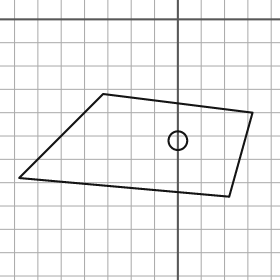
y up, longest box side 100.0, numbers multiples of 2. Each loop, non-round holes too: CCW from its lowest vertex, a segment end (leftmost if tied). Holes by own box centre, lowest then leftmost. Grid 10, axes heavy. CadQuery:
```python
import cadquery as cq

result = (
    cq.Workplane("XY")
    .moveTo(22.0, -76.0)
    .lineTo(32.0, -40.0)
    .lineTo(-32.0, -32.0)
    .lineTo(-68.0, -68.0)
    .close()
    .moveTo(0.0, -52.0)
    .circle(4.0)
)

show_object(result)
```